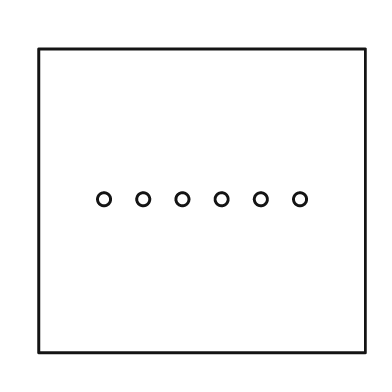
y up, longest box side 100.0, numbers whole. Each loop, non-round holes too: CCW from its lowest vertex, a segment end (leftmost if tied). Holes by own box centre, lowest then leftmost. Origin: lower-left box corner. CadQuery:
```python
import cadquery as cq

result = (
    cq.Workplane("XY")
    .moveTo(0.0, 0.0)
    .lineTo(100.0, 0.0)
    .lineTo(100.0, 93.0)
    .lineTo(0.0, 93.0)
    .close()
    .moveTo(20.0, 47.0)
    .circle(2.0)
    .moveTo(32.0, 47.0)
    .circle(2.0)
    .moveTo(44.0, 47.0)
    .circle(2.0)
    .moveTo(56.0, 47.0)
    .circle(2.0)
    .moveTo(68.0, 47.0)
    .circle(2.0)
    .moveTo(80.0, 47.0)
    .circle(2.0)
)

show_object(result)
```